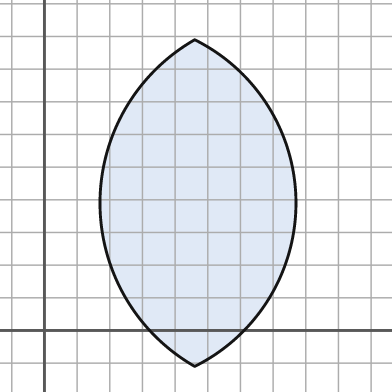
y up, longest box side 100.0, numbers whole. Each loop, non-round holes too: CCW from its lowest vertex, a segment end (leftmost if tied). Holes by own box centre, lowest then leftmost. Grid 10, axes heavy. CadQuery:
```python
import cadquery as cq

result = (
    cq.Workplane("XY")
    .moveTo(46.0, -11.0)
    .threePointArc((77.0, 39.0), (46.0, 89.0))
    .threePointArc((17.0, 39.0), (46.0, -11.0))
    .close()
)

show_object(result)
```